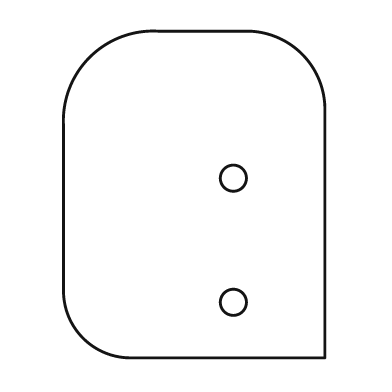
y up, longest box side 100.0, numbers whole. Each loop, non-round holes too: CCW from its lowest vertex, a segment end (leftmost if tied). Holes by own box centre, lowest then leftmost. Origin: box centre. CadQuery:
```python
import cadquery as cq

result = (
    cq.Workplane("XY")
    .moveTo(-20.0, -50.0)
    .lineTo(40.0, -50.0)
    .lineTo(40.0, 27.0)
    .threePointArc((33.0, 43.0), (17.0, 50.0))
    .lineTo(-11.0, 50.0)
    .threePointArc((-32.0, 42.0), (-40.0, 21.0))
    .lineTo(-40.0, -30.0)
    .threePointArc((-34.0, -44.0), (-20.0, -50.0))
    .close()
    .moveTo(12.0, -33.0)
    .circle(4.0)
    .moveTo(12.0, 5.0)
    .circle(4.0)
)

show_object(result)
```